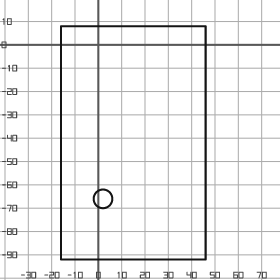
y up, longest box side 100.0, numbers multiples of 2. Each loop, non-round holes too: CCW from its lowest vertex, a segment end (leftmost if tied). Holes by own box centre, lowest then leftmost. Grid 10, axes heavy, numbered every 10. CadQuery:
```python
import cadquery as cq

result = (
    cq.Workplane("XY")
    .moveTo(-16.0, -92.0)
    .lineTo(46.0, -92.0)
    .lineTo(46.0, 8.0)
    .lineTo(-16.0, 8.0)
    .close()
    .moveTo(2.0, -66.0)
    .circle(4.0)
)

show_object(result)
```